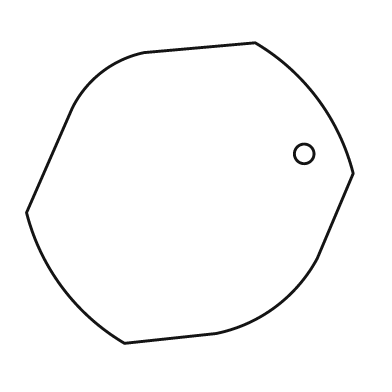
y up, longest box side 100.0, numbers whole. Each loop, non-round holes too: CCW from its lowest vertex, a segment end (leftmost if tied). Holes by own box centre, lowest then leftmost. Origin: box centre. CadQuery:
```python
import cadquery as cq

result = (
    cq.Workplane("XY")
    .moveTo(-20.0, -46.0)
    .lineTo(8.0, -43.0)
    .threePointArc((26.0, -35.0), (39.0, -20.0))
    .lineTo(50.0, 6.0)
    .threePointArc((39.0, 29.0), (20.0, 46.0))
    .lineTo(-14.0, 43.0)
    .threePointArc((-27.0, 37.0), (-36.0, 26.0))
    .lineTo(-50.0, -6.0)
    .threePointArc((-39.0, -29.0), (-20.0, -46.0))
    .close()
    .moveTo(35.0, 12.0)
    .circle(3.0)
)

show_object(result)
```